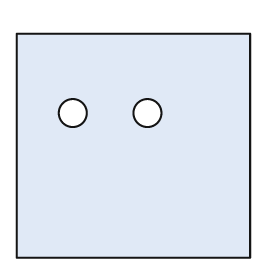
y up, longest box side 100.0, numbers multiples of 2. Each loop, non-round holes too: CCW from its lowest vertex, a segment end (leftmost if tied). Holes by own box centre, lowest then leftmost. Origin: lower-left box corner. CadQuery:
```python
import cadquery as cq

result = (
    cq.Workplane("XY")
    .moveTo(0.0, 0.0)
    .lineTo(100.0, 0.0)
    .lineTo(100.0, 96.0)
    .lineTo(0.0, 96.0)
    .close()
    .moveTo(24.0, 62.0)
    .circle(6.0)
    .moveTo(56.0, 62.0)
    .circle(6.0)
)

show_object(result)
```